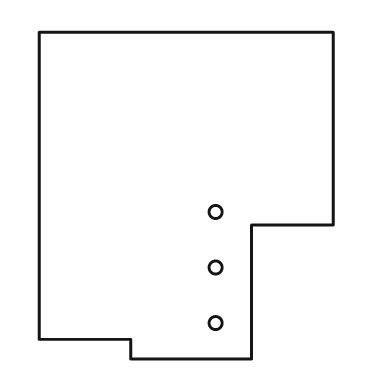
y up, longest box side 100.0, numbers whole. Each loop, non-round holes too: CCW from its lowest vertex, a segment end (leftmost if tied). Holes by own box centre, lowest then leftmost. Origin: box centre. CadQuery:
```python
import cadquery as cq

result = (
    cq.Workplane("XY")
    .moveTo(-17.0, -50.0)
    .lineTo(20.0, -50.0)
    .lineTo(20.0, -9.0)
    .lineTo(45.0, -9.0)
    .lineTo(45.0, 50.0)
    .lineTo(-45.0, 50.0)
    .lineTo(-45.0, -44.0)
    .lineTo(-17.0, -44.0)
    .close()
    .moveTo(9.0, -39.0)
    .circle(2.0)
    .moveTo(9.0, -22.0)
    .circle(2.0)
    .moveTo(9.0, -5.0)
    .circle(2.0)
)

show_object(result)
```